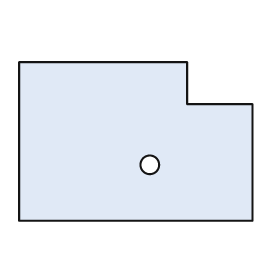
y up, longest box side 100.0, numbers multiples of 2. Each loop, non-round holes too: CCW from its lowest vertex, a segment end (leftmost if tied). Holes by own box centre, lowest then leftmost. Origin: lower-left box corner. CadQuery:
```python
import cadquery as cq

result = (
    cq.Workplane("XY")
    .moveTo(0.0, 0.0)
    .lineTo(100.0, 0.0)
    .lineTo(100.0, 50.0)
    .lineTo(72.0, 50.0)
    .lineTo(72.0, 68.0)
    .lineTo(0.0, 68.0)
    .close()
    .moveTo(56.0, 24.0)
    .circle(4.0)
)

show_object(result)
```